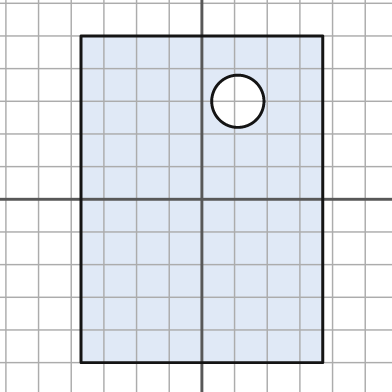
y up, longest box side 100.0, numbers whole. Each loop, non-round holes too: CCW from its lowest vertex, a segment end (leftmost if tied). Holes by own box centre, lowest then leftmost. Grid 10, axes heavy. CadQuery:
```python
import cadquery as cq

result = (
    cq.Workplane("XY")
    .moveTo(-37.0, -50.0)
    .lineTo(37.0, -50.0)
    .lineTo(37.0, 50.0)
    .lineTo(-37.0, 50.0)
    .close()
    .moveTo(11.0, 30.0)
    .circle(8.0)
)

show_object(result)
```